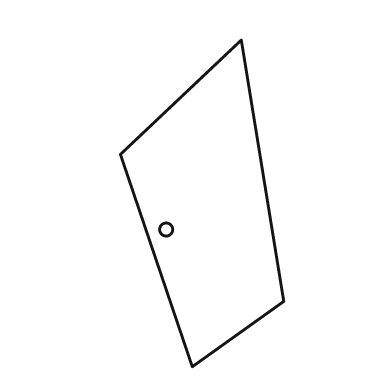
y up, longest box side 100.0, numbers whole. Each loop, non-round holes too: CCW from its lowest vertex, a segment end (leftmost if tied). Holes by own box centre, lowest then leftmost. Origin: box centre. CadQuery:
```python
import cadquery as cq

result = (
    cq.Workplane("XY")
    .moveTo(-3.0, -50.0)
    .lineTo(25.0, -30.0)
    .lineTo(12.0, 50.0)
    .lineTo(-25.0, 15.0)
    .close()
    .moveTo(-11.0, -8.0)
    .circle(2.0)
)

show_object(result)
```